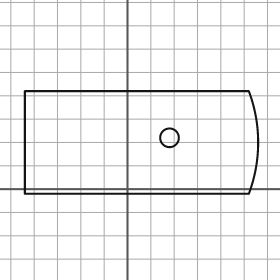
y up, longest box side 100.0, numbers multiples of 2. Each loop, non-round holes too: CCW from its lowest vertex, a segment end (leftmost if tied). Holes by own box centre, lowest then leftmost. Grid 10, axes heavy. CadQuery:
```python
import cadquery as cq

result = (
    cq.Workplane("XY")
    .moveTo(-44.0, -2.0)
    .lineTo(52.0, -2.0)
    .threePointArc((56.0, 20.0), (52.0, 42.0))
    .lineTo(-44.0, 42.0)
    .close()
    .moveTo(18.0, 22.0)
    .circle(4.0)
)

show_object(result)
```